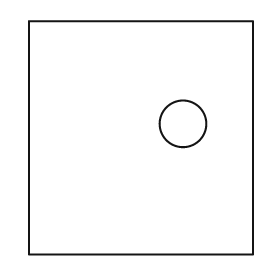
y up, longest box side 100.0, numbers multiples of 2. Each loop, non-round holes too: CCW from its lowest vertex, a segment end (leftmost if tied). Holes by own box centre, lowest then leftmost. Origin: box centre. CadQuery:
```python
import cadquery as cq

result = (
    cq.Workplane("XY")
    .moveTo(-48.0, -50.0)
    .lineTo(48.0, -50.0)
    .lineTo(48.0, 50.0)
    .lineTo(-48.0, 50.0)
    .close()
    .moveTo(18.0, 6.0)
    .circle(10.0)
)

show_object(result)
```